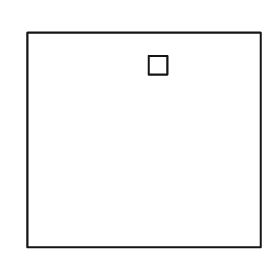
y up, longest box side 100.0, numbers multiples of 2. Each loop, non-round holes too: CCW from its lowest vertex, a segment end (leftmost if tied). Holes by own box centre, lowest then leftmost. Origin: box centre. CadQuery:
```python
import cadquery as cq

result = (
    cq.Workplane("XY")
    .moveTo(-50.0, -46.0)
    .lineTo(50.0, -46.0)
    .lineTo(50.0, 46.0)
    .lineTo(-50.0, 46.0)
    .close()
    .moveTo(2.0, 28.0)
    .lineTo(10.0, 28.0)
    .lineTo(10.0, 36.0)
    .lineTo(2.0, 36.0)
    .close()
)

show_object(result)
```